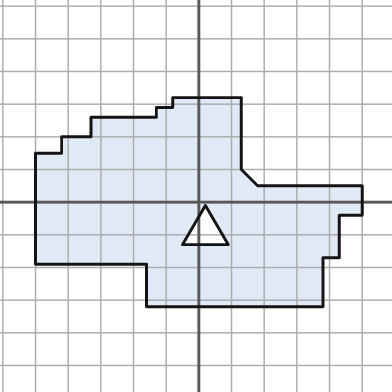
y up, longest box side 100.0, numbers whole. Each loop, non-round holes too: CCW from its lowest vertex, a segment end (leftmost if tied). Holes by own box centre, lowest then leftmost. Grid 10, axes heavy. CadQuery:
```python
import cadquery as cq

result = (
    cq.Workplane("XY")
    .moveTo(-16.0, -32.0)
    .lineTo(38.0, -32.0)
    .lineTo(38.0, -17.0)
    .lineTo(43.0, -17.0)
    .lineTo(43.0, -4.0)
    .lineTo(50.0, -4.0)
    .lineTo(50.0, 5.0)
    .lineTo(18.0, 5.0)
    .lineTo(13.0, 10.0)
    .lineTo(13.0, 32.0)
    .lineTo(-8.0, 32.0)
    .lineTo(-8.0, 29.0)
    .lineTo(-13.0, 29.0)
    .lineTo(-13.0, 26.0)
    .lineTo(-33.0, 26.0)
    .lineTo(-33.0, 20.0)
    .lineTo(-42.0, 20.0)
    .lineTo(-42.0, 15.0)
    .lineTo(-50.0, 15.0)
    .lineTo(-50.0, -19.0)
    .lineTo(-16.0, -19.0)
    .close()
    .moveTo(-5.0, -13.0)
    .lineTo(9.0, -13.0)
    .lineTo(2.0, -1.0)
    .close()
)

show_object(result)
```